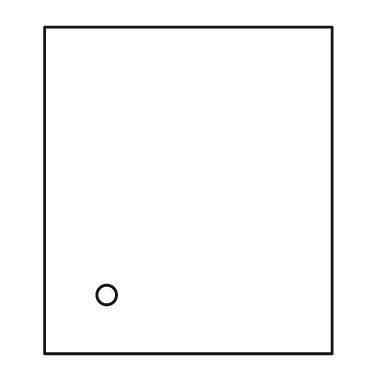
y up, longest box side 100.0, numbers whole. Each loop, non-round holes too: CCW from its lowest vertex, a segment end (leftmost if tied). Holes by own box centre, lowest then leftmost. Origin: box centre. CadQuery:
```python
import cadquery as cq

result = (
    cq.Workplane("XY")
    .moveTo(-44.0, -50.0)
    .lineTo(44.0, -50.0)
    .lineTo(44.0, 50.0)
    .lineTo(-44.0, 50.0)
    .close()
    .moveTo(-25.0, -32.0)
    .circle(3.0)
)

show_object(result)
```